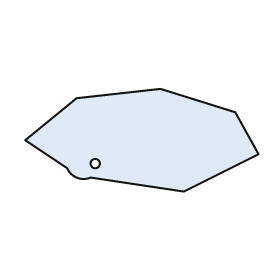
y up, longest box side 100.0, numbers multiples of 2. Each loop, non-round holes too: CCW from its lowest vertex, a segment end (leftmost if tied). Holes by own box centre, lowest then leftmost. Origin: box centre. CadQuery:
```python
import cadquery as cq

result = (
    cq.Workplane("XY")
    .moveTo(18.0, -22.0)
    .lineTo(50.0, -6.0)
    .lineTo(40.0, 12.0)
    .lineTo(8.0, 22.0)
    .lineTo(-28.0, 18.0)
    .lineTo(-50.0, 0.0)
    .lineTo(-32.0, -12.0)
    .threePointArc((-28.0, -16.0), (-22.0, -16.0))
    .close()
    .moveTo(-20.0, -10.0)
    .circle(2.0)
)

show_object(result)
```